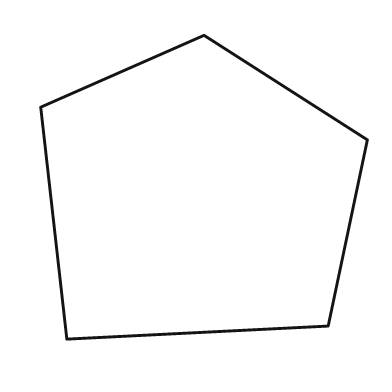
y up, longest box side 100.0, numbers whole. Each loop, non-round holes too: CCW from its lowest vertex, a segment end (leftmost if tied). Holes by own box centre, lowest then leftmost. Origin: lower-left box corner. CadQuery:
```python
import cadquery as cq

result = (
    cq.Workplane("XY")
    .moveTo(8.0, 0.0)
    .lineTo(88.0, 4.0)
    .lineTo(100.0, 61.0)
    .lineTo(50.0, 93.0)
    .lineTo(0.0, 71.0)
    .close()
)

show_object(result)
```